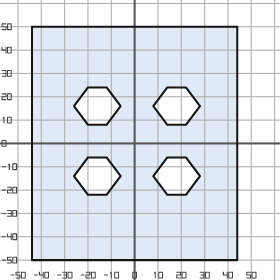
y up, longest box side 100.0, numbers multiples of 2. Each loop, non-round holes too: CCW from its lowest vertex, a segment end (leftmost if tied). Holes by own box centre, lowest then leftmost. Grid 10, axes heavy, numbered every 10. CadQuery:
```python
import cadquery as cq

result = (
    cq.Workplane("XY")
    .moveTo(-44.0, -50.0)
    .lineTo(44.0, -50.0)
    .lineTo(44.0, 50.0)
    .lineTo(-44.0, 50.0)
    .close()
    .moveTo(-20.0, -22.0)
    .lineTo(-12.0, -22.0)
    .lineTo(-6.0, -14.0)
    .lineTo(-12.0, -6.0)
    .lineTo(-20.0, -6.0)
    .lineTo(-26.0, -14.0)
    .close()
    .moveTo(14.0, -22.0)
    .lineTo(22.0, -22.0)
    .lineTo(28.0, -14.0)
    .lineTo(22.0, -6.0)
    .lineTo(14.0, -6.0)
    .lineTo(8.0, -14.0)
    .close()
    .moveTo(-20.0, 8.0)
    .lineTo(-12.0, 8.0)
    .lineTo(-6.0, 16.0)
    .lineTo(-12.0, 24.0)
    .lineTo(-20.0, 24.0)
    .lineTo(-26.0, 16.0)
    .close()
    .moveTo(14.0, 8.0)
    .lineTo(22.0, 8.0)
    .lineTo(28.0, 16.0)
    .lineTo(22.0, 24.0)
    .lineTo(14.0, 24.0)
    .lineTo(8.0, 16.0)
    .close()
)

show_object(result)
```